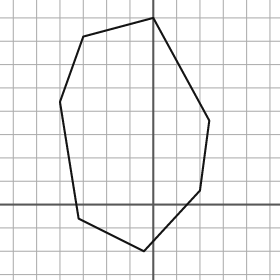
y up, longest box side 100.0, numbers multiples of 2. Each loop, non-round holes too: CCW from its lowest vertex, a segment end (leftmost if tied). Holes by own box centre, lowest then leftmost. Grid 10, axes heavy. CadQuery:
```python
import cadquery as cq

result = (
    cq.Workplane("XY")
    .moveTo(-4.0, -20.0)
    .lineTo(20.0, 6.0)
    .lineTo(24.0, 36.0)
    .lineTo(0.0, 80.0)
    .lineTo(-30.0, 72.0)
    .lineTo(-40.0, 44.0)
    .lineTo(-32.0, -6.0)
    .close()
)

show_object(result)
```